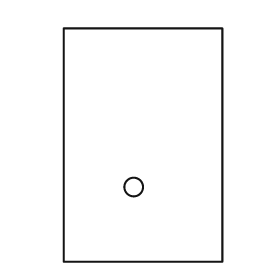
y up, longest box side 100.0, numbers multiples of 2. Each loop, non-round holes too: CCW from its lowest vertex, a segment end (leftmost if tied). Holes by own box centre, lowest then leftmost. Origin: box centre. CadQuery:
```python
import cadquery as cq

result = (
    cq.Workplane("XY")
    .moveTo(-34.0, -50.0)
    .lineTo(34.0, -50.0)
    .lineTo(34.0, 50.0)
    .lineTo(-34.0, 50.0)
    .close()
    .moveTo(-4.0, -18.0)
    .circle(4.0)
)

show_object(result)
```